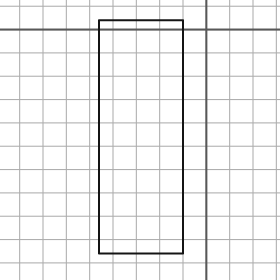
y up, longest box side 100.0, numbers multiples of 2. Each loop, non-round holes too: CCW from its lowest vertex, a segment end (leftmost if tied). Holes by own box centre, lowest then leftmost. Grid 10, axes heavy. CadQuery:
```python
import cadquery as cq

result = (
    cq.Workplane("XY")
    .moveTo(-46.0, -96.0)
    .lineTo(-10.0, -96.0)
    .lineTo(-10.0, 4.0)
    .lineTo(-46.0, 4.0)
    .close()
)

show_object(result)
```